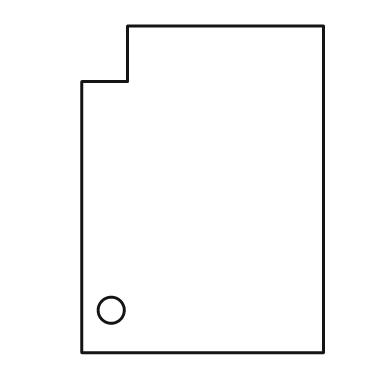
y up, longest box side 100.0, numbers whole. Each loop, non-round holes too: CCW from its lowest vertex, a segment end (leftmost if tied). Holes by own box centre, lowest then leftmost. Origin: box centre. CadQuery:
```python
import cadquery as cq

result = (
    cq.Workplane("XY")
    .moveTo(-37.0, -50.0)
    .lineTo(37.0, -50.0)
    .lineTo(37.0, 50.0)
    .lineTo(-23.0, 50.0)
    .lineTo(-23.0, 33.0)
    .lineTo(-37.0, 33.0)
    .close()
    .moveTo(-28.0, -37.0)
    .circle(4.0)
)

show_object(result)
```